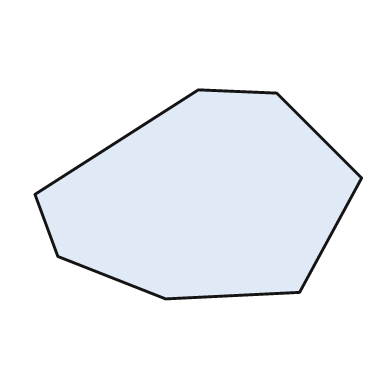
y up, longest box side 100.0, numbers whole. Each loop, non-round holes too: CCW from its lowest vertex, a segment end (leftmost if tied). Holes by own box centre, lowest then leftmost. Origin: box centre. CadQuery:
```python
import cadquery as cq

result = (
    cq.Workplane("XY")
    .moveTo(-10.0, -32.0)
    .lineTo(31.0, -30.0)
    .lineTo(50.0, 5.0)
    .lineTo(24.0, 31.0)
    .lineTo(0.0, 32.0)
    .lineTo(-50.0, 0.0)
    .lineTo(-43.0, -19.0)
    .close()
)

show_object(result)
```